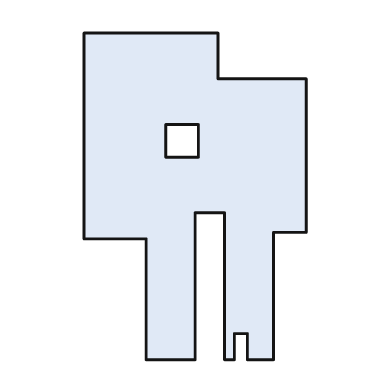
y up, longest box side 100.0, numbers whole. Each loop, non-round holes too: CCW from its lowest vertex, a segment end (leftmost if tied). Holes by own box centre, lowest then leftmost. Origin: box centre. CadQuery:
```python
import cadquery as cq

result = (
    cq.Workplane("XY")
    .moveTo(-15.0, -50.0)
    .lineTo(0.0, -50.0)
    .lineTo(0.0, -5.0)
    .lineTo(9.0, -5.0)
    .lineTo(9.0, -50.0)
    .lineTo(12.0, -50.0)
    .lineTo(12.0, -42.0)
    .lineTo(16.0, -42.0)
    .lineTo(16.0, -50.0)
    .lineTo(24.0, -50.0)
    .lineTo(24.0, -11.0)
    .lineTo(34.0, -11.0)
    .lineTo(34.0, 36.0)
    .lineTo(7.0, 36.0)
    .lineTo(7.0, 50.0)
    .lineTo(-34.0, 50.0)
    .lineTo(-34.0, -13.0)
    .lineTo(-15.0, -13.0)
    .close()
    .moveTo(-9.0, 12.0)
    .lineTo(1.0, 12.0)
    .lineTo(1.0, 22.0)
    .lineTo(-9.0, 22.0)
    .close()
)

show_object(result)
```